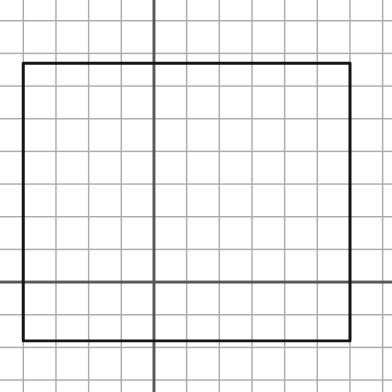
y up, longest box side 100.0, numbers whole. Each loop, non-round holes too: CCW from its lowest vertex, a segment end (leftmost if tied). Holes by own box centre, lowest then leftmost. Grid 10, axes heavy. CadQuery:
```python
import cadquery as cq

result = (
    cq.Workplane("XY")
    .moveTo(-40.0, -18.0)
    .lineTo(60.0, -18.0)
    .lineTo(60.0, 67.0)
    .lineTo(-40.0, 67.0)
    .close()
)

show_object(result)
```